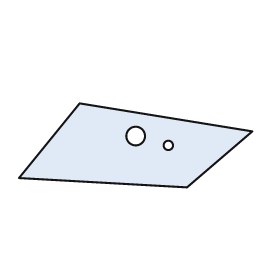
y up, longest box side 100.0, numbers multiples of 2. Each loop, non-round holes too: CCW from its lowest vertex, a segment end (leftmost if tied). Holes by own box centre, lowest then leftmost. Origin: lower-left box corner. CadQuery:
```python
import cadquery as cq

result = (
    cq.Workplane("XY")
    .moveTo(72.0, 0.0)
    .lineTo(100.0, 24.0)
    .lineTo(26.0, 36.0)
    .lineTo(0.0, 4.0)
    .close()
    .moveTo(64.0, 18.0)
    .circle(2.0)
    .moveTo(50.0, 22.0)
    .circle(4.0)
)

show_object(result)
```